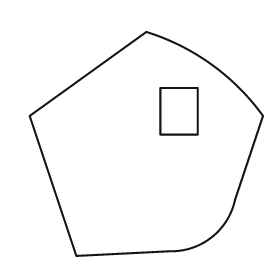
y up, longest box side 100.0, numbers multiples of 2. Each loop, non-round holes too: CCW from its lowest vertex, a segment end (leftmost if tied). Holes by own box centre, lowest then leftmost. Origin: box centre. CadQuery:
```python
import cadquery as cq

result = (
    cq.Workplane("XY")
    .moveTo(-30.0, -48.0)
    .lineTo(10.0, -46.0)
    .threePointArc((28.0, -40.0), (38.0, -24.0))
    .lineTo(50.0, 12.0)
    .threePointArc((28.0, 34.0), (0.0, 48.0))
    .lineTo(-50.0, 12.0)
    .close()
    .moveTo(6.0, 4.0)
    .lineTo(22.0, 4.0)
    .lineTo(22.0, 24.0)
    .lineTo(6.0, 24.0)
    .close()
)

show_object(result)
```